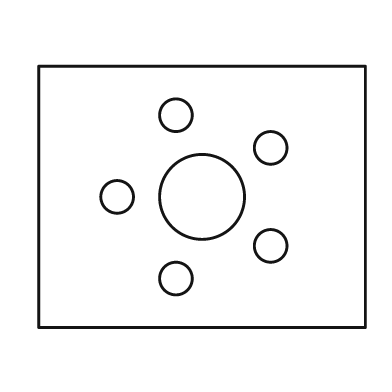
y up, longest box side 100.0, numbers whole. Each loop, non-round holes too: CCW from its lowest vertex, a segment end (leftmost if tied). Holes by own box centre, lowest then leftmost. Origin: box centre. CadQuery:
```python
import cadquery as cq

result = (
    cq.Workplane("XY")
    .moveTo(-50.0, -40.0)
    .lineTo(50.0, -40.0)
    .lineTo(50.0, 40.0)
    .lineTo(-50.0, 40.0)
    .close()
    .moveTo(-8.0, -25.0)
    .circle(5.0)
    .moveTo(21.0, -15.0)
    .circle(5.0)
    .moveTo(-26.0, 0.0)
    .circle(5.0)
    .moveTo(0.0, 0.0)
    .circle(13.0)
    .moveTo(21.0, 15.0)
    .circle(5.0)
    .moveTo(-8.0, 25.0)
    .circle(5.0)
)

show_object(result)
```